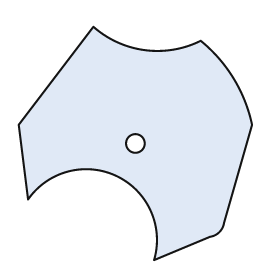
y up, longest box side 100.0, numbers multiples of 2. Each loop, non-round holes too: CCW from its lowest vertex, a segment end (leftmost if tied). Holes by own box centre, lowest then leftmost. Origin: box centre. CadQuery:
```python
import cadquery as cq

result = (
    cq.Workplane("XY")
    .moveTo(8.0, -50.0)
    .lineTo(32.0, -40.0)
    .threePointArc((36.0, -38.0), (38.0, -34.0))
    .lineTo(50.0, 8.0)
    .threePointArc((42.0, 28.0), (28.0, 44.0))
    .threePointArc((4.0, 40.0), (-18.0, 50.0))
    .lineTo(-50.0, 8.0)
    .lineTo(-46.0, -24.0)
    .threePointArc((-8.0, -14.0), (8.0, -50.0))
    .close()
    .moveTo(0.0, 0.0)
    .circle(4.0)
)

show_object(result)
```